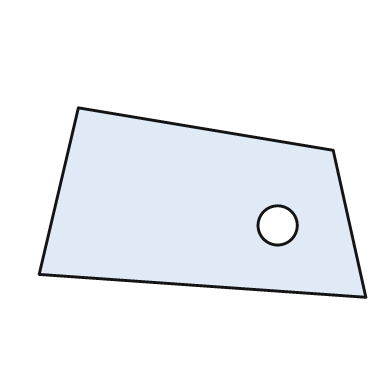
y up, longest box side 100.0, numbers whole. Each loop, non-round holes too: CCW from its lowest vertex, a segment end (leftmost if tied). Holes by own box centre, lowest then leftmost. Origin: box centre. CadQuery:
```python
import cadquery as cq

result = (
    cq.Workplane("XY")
    .moveTo(50.0, -29.0)
    .lineTo(40.0, 16.0)
    .lineTo(-38.0, 29.0)
    .lineTo(-50.0, -22.0)
    .close()
    .moveTo(23.0, -7.0)
    .circle(6.0)
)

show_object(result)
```